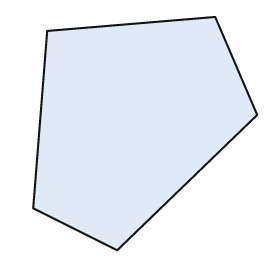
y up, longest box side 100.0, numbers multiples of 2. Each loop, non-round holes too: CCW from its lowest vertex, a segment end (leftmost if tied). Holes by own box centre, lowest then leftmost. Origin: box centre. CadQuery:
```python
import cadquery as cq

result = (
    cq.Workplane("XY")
    .moveTo(-12.0, -50.0)
    .lineTo(48.0, 8.0)
    .lineTo(30.0, 50.0)
    .lineTo(-42.0, 44.0)
    .lineTo(-48.0, -32.0)
    .close()
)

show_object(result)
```